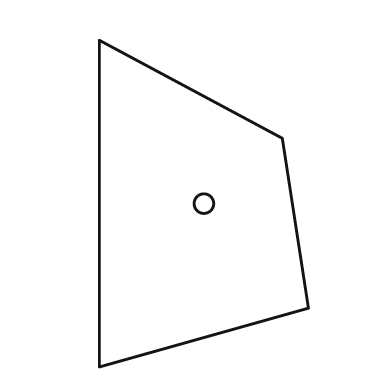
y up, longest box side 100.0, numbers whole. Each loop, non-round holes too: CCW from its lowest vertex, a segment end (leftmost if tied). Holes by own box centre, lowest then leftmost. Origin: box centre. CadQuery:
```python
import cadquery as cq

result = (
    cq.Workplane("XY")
    .moveTo(-32.0, -50.0)
    .lineTo(32.0, -32.0)
    .lineTo(24.0, 20.0)
    .lineTo(-32.0, 50.0)
    .close()
    .moveTo(0.0, 0.0)
    .circle(3.0)
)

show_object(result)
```